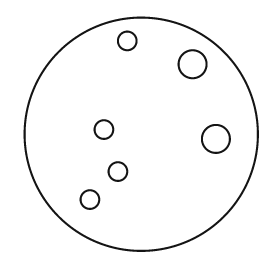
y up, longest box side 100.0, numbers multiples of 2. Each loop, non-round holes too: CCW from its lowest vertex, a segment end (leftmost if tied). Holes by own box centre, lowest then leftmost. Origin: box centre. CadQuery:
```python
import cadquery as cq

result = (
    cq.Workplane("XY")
    .moveTo(0.0, 0.0)
    .circle(50.0)
    .moveTo(-22.0, -28.0)
    .circle(4.0)
    .moveTo(-10.0, -16.0)
    .circle(4.0)
    .moveTo(32.0, -2.0)
    .circle(6.0)
    .moveTo(-16.0, 2.0)
    .circle(4.0)
    .moveTo(22.0, 30.0)
    .circle(6.0)
    .moveTo(-6.0, 40.0)
    .circle(4.0)
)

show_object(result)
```